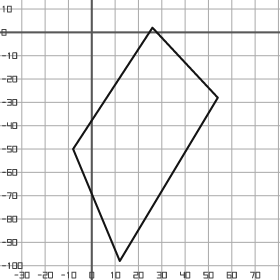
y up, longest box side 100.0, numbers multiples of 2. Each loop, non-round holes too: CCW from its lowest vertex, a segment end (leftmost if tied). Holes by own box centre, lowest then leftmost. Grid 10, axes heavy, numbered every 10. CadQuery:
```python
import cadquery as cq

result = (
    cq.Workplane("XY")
    .moveTo(12.0, -98.0)
    .lineTo(54.0, -28.0)
    .lineTo(26.0, 2.0)
    .lineTo(-8.0, -50.0)
    .close()
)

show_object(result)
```